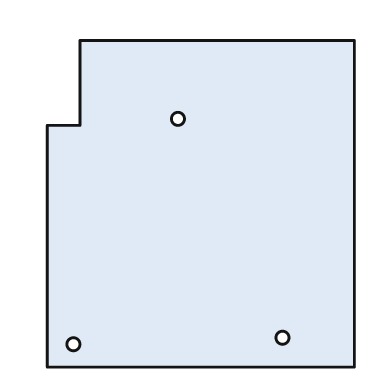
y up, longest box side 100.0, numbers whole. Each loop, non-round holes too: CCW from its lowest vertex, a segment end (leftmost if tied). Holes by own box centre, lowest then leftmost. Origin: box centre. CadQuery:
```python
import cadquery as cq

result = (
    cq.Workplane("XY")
    .moveTo(-47.0, -50.0)
    .lineTo(47.0, -50.0)
    .lineTo(47.0, 50.0)
    .lineTo(-37.0, 50.0)
    .lineTo(-37.0, 24.0)
    .lineTo(-47.0, 24.0)
    .close()
    .moveTo(-39.0, -43.0)
    .circle(2.0)
    .moveTo(25.0, -41.0)
    .circle(2.0)
    .moveTo(-7.0, 26.0)
    .circle(2.0)
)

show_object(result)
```